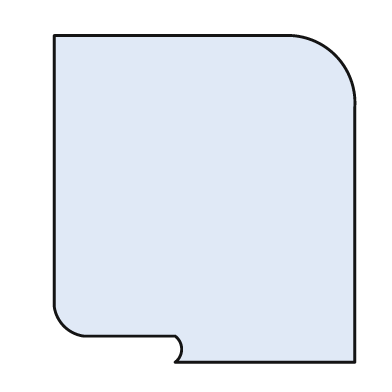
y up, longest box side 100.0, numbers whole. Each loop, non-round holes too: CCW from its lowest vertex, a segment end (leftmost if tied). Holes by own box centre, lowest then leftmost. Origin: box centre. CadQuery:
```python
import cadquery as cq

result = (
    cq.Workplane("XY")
    .moveTo(-9.0, -50.0)
    .lineTo(46.0, -50.0)
    .lineTo(46.0, 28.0)
    .threePointArc((40.0, 44.0), (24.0, 50.0))
    .lineTo(-46.0, 50.0)
    .lineTo(-46.0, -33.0)
    .threePointArc((-43.0, -39.0), (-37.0, -42.0))
    .lineTo(-9.0, -42.0)
    .threePointArc((-7.0, -46.0), (-9.0, -50.0))
    .close()
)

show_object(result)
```